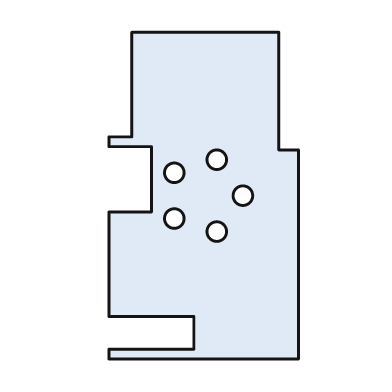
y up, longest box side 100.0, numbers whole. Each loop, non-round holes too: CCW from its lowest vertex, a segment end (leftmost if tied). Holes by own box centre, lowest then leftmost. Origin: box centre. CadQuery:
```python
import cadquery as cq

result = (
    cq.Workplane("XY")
    .moveTo(-29.0, -50.0)
    .lineTo(29.0, -50.0)
    .lineTo(29.0, 14.0)
    .lineTo(23.0, 14.0)
    .lineTo(23.0, 50.0)
    .lineTo(-22.0, 50.0)
    .lineTo(-22.0, 18.0)
    .lineTo(-29.0, 18.0)
    .lineTo(-29.0, 15.0)
    .lineTo(-16.0, 15.0)
    .lineTo(-16.0, -5.0)
    .lineTo(-29.0, -5.0)
    .lineTo(-29.0, -37.0)
    .lineTo(-3.0, -37.0)
    .lineTo(-3.0, -47.0)
    .lineTo(-29.0, -47.0)
    .close()
    .moveTo(4.0, -11.0)
    .circle(3.0)
    .moveTo(-9.0, -7.0)
    .circle(3.0)
    .moveTo(12.0, 0.0)
    .circle(3.0)
    .moveTo(-9.0, 7.0)
    .circle(3.0)
    .moveTo(4.0, 11.0)
    .circle(3.0)
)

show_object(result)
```